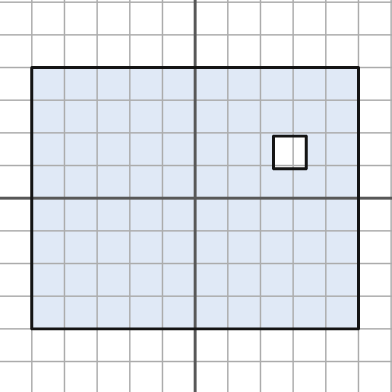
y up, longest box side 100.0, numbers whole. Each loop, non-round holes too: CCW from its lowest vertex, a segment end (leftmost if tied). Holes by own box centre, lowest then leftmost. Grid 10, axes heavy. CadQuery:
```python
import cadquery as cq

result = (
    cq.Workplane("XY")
    .moveTo(-50.0, -40.0)
    .lineTo(50.0, -40.0)
    .lineTo(50.0, 40.0)
    .lineTo(-50.0, 40.0)
    .close()
    .moveTo(24.0, 9.0)
    .lineTo(34.0, 9.0)
    .lineTo(34.0, 19.0)
    .lineTo(24.0, 19.0)
    .close()
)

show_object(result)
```